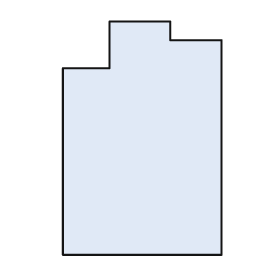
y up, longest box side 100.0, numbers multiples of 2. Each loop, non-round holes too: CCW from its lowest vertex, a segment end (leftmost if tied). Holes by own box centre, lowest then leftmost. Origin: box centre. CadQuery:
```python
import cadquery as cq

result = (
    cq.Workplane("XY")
    .moveTo(-34.0, -50.0)
    .lineTo(34.0, -50.0)
    .lineTo(34.0, 42.0)
    .lineTo(12.0, 42.0)
    .lineTo(12.0, 50.0)
    .lineTo(-14.0, 50.0)
    .lineTo(-14.0, 30.0)
    .lineTo(-34.0, 30.0)
    .close()
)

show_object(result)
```